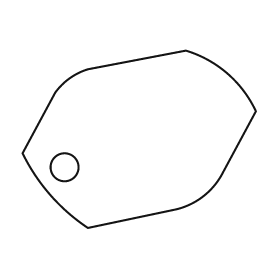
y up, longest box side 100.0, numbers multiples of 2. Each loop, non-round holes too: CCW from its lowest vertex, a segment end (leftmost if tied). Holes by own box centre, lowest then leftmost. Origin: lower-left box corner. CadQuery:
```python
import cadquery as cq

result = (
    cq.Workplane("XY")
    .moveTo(28.0, 0.0)
    .lineTo(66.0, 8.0)
    .threePointArc((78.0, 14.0), (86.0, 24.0))
    .lineTo(100.0, 50.0)
    .threePointArc((88.0, 66.0), (70.0, 76.0))
    .lineTo(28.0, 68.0)
    .threePointArc((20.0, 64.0), (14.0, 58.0))
    .lineTo(0.0, 32.0)
    .threePointArc((12.0, 14.0), (28.0, 0.0))
    .close()
    .moveTo(18.0, 26.0)
    .circle(6.0)
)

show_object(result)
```